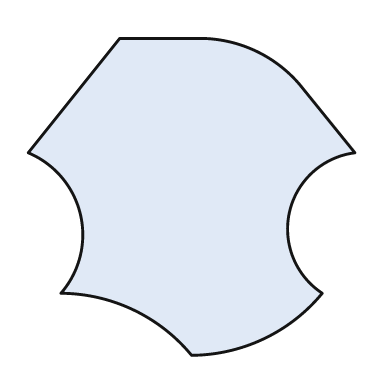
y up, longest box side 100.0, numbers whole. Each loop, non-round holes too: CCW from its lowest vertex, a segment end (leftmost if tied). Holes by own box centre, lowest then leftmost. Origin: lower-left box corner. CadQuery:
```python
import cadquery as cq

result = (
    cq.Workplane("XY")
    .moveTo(50.0, 0.0)
    .threePointArc((72.0, 5.0), (90.0, 19.0))
    .threePointArc((80.0, 44.0), (100.0, 62.0))
    .lineTo(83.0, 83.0)
    .threePointArc((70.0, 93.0), (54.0, 97.0))
    .lineTo(28.0, 97.0)
    .lineTo(0.0, 62.0)
    .threePointArc((16.0, 43.0), (10.0, 19.0))
    .threePointArc((32.0, 14.0), (50.0, 0.0))
    .close()
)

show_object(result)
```